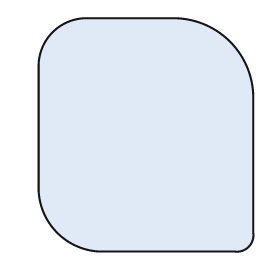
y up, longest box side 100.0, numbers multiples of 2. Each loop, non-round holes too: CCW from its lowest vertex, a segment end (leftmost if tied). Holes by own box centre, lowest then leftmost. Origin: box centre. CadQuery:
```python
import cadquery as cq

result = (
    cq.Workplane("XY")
    .moveTo(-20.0, -50.0)
    .lineTo(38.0, -50.0)
    .threePointArc((44.0, -48.0), (46.0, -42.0))
    .lineTo(46.0, 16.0)
    .threePointArc((36.0, 40.0), (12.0, 50.0))
    .lineTo(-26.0, 50.0)
    .threePointArc((-40.0, 44.0), (-46.0, 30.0))
    .lineTo(-46.0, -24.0)
    .threePointArc((-38.0, -42.0), (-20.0, -50.0))
    .close()
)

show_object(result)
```